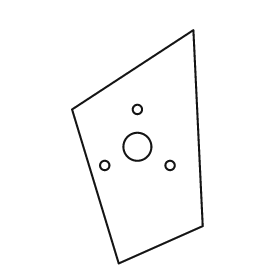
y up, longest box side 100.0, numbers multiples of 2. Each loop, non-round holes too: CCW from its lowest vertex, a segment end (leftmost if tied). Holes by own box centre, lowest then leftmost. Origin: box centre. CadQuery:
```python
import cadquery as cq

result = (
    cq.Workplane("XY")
    .moveTo(-8.0, -50.0)
    .lineTo(28.0, -34.0)
    .lineTo(24.0, 50.0)
    .lineTo(-28.0, 16.0)
    .close()
    .moveTo(-14.0, -8.0)
    .circle(2.0)
    .moveTo(14.0, -8.0)
    .circle(2.0)
    .moveTo(0.0, 0.0)
    .circle(6.0)
    .moveTo(0.0, 16.0)
    .circle(2.0)
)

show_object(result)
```